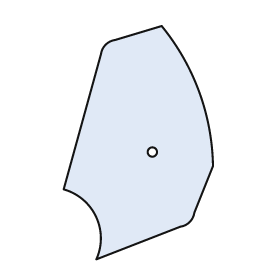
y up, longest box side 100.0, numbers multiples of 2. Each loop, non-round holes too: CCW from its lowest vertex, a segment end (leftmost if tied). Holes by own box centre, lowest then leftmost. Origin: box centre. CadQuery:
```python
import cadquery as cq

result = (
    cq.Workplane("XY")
    .moveTo(-18.0, -50.0)
    .lineTo(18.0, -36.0)
    .threePointArc((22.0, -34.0), (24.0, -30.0))
    .lineTo(32.0, -10.0)
    .threePointArc((26.0, 22.0), (10.0, 50.0))
    .lineTo(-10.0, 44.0)
    .threePointArc((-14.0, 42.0), (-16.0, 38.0))
    .lineTo(-32.0, -20.0)
    .threePointArc((-18.0, -32.0), (-18.0, -50.0))
    .close()
    .moveTo(6.0, -4.0)
    .circle(2.0)
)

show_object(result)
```